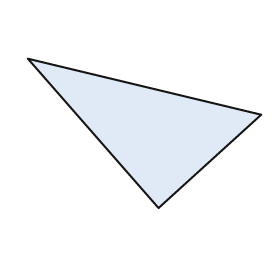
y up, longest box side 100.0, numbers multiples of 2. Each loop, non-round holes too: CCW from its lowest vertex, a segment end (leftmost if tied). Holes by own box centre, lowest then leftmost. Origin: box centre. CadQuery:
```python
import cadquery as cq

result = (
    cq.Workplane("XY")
    .moveTo(6.0, -32.0)
    .lineTo(50.0, 8.0)
    .lineTo(-50.0, 32.0)
    .close()
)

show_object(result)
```